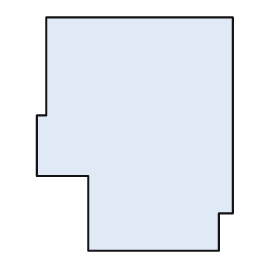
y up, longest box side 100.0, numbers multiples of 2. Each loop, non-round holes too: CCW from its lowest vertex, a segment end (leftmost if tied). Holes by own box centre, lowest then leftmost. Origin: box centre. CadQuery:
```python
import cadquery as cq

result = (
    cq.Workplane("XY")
    .moveTo(-20.0, -50.0)
    .lineTo(36.0, -50.0)
    .lineTo(36.0, -34.0)
    .lineTo(42.0, -34.0)
    .lineTo(42.0, 50.0)
    .lineTo(-38.0, 50.0)
    .lineTo(-38.0, 8.0)
    .lineTo(-42.0, 8.0)
    .lineTo(-42.0, -18.0)
    .lineTo(-20.0, -18.0)
    .close()
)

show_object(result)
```